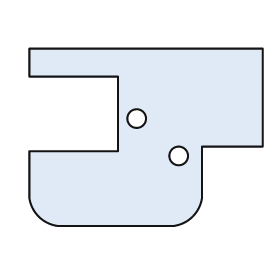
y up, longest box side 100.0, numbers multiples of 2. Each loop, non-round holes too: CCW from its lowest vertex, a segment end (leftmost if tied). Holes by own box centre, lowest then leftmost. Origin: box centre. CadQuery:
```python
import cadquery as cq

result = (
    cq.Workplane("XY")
    .moveTo(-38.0, -38.0)
    .lineTo(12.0, -38.0)
    .threePointArc((20.0, -34.0), (24.0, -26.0))
    .lineTo(24.0, -4.0)
    .lineTo(50.0, -4.0)
    .lineTo(50.0, 38.0)
    .lineTo(-50.0, 38.0)
    .lineTo(-50.0, 26.0)
    .lineTo(-12.0, 26.0)
    .lineTo(-12.0, -6.0)
    .lineTo(-50.0, -6.0)
    .lineTo(-50.0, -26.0)
    .threePointArc((-46.0, -34.0), (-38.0, -38.0))
    .close()
    .moveTo(14.0, -8.0)
    .circle(4.0)
    .moveTo(-4.0, 8.0)
    .circle(4.0)
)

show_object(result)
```